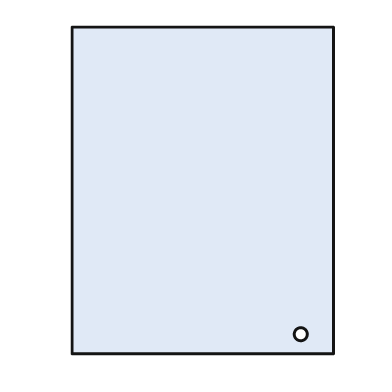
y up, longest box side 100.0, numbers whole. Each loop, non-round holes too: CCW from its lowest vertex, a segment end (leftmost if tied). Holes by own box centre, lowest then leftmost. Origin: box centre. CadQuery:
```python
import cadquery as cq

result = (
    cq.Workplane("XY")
    .moveTo(-40.0, -50.0)
    .lineTo(40.0, -50.0)
    .lineTo(40.0, 50.0)
    .lineTo(-40.0, 50.0)
    .close()
    .moveTo(30.0, -44.0)
    .circle(2.0)
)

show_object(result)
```